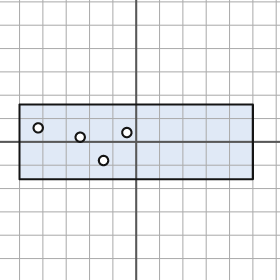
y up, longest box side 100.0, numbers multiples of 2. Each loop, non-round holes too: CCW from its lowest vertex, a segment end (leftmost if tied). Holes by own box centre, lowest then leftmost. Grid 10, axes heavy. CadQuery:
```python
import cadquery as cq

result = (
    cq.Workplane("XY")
    .moveTo(-50.0, -16.0)
    .lineTo(50.0, -16.0)
    .lineTo(50.0, 16.0)
    .lineTo(-50.0, 16.0)
    .close()
    .moveTo(-14.0, -8.0)
    .circle(2.0)
    .moveTo(-24.0, 2.0)
    .circle(2.0)
    .moveTo(-4.0, 4.0)
    .circle(2.0)
    .moveTo(-42.0, 6.0)
    .circle(2.0)
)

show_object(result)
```